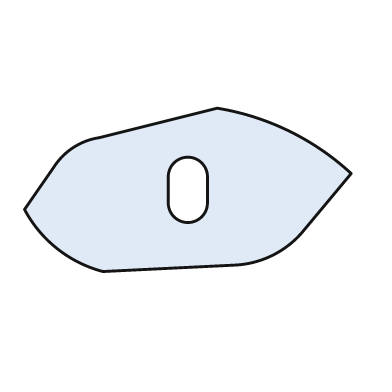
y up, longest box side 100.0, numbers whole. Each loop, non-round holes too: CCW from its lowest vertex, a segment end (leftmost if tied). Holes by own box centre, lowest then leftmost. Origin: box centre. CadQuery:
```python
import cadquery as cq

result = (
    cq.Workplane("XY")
    .moveTo(-26.0, -25.0)
    .lineTo(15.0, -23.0)
    .threePointArc((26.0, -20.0), (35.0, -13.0))
    .lineTo(50.0, 5.0)
    .threePointArc((31.0, 18.0), (9.0, 25.0))
    .lineTo(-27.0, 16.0)
    .threePointArc((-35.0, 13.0), (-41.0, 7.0))
    .lineTo(-50.0, -6.0)
    .threePointArc((-40.0, -18.0), (-26.0, -25.0))
    .close()
    .moveTo(-6.0, -4.0)
    .threePointArc((0.0, -10.0), (6.0, -4.0))
    .lineTo(6.0, 4.0)
    .threePointArc((0.0, 10.0), (-6.0, 4.0))
    .close()
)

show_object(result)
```